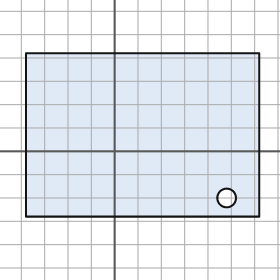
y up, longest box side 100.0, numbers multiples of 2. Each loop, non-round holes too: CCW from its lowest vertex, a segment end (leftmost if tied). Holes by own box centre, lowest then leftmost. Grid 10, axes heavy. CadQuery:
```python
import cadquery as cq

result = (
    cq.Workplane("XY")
    .moveTo(-38.0, -28.0)
    .lineTo(62.0, -28.0)
    .lineTo(62.0, 42.0)
    .lineTo(-38.0, 42.0)
    .close()
    .moveTo(48.0, -20.0)
    .circle(4.0)
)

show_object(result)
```